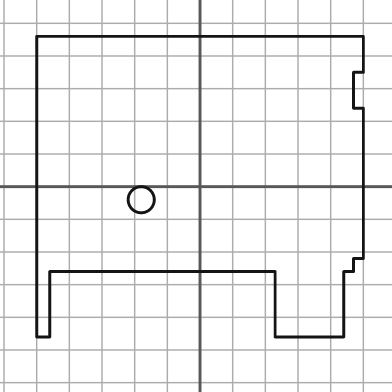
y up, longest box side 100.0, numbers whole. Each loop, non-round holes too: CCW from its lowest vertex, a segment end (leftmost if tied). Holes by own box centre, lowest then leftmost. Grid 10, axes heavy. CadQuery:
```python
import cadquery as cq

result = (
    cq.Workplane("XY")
    .moveTo(-50.0, -46.0)
    .lineTo(-46.0, -46.0)
    .lineTo(-46.0, -26.0)
    .lineTo(23.0, -26.0)
    .lineTo(23.0, -46.0)
    .lineTo(44.0, -46.0)
    .lineTo(44.0, -26.0)
    .lineTo(47.0, -26.0)
    .lineTo(47.0, -22.0)
    .lineTo(50.0, -22.0)
    .lineTo(50.0, 24.0)
    .lineTo(47.0, 24.0)
    .lineTo(47.0, 35.0)
    .lineTo(50.0, 35.0)
    .lineTo(50.0, 46.0)
    .lineTo(-50.0, 46.0)
    .close()
    .moveTo(-18.0, -4.0)
    .circle(4.0)
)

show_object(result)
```